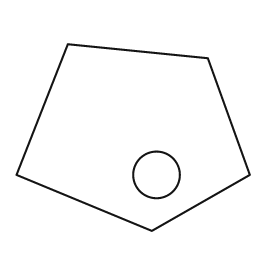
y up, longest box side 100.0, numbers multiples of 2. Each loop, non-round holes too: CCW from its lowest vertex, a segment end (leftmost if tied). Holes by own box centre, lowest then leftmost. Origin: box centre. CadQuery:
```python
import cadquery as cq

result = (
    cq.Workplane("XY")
    .moveTo(8.0, -40.0)
    .lineTo(50.0, -16.0)
    .lineTo(32.0, 34.0)
    .lineTo(-28.0, 40.0)
    .lineTo(-50.0, -16.0)
    .close()
    .moveTo(10.0, -16.0)
    .circle(10.0)
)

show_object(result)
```